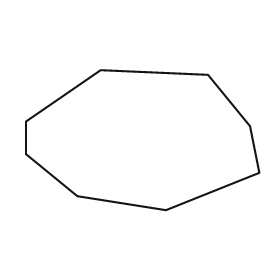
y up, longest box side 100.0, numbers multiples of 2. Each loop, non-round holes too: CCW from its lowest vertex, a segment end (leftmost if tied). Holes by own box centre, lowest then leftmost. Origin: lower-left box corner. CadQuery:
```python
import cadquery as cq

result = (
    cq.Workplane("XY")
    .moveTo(60.0, 0.0)
    .lineTo(100.0, 16.0)
    .lineTo(96.0, 36.0)
    .lineTo(78.0, 58.0)
    .lineTo(32.0, 60.0)
    .lineTo(0.0, 38.0)
    .lineTo(0.0, 24.0)
    .lineTo(22.0, 6.0)
    .close()
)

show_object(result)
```